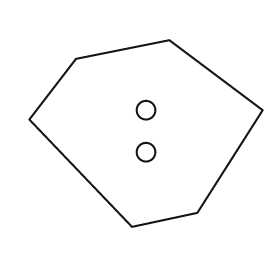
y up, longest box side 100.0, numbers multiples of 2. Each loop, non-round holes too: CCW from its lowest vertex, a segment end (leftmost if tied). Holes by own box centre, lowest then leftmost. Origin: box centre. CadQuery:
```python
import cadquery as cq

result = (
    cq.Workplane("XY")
    .moveTo(-6.0, -40.0)
    .lineTo(22.0, -34.0)
    .lineTo(50.0, 10.0)
    .lineTo(10.0, 40.0)
    .lineTo(-30.0, 32.0)
    .lineTo(-50.0, 6.0)
    .close()
    .moveTo(0.0, -8.0)
    .circle(4.0)
    .moveTo(0.0, 10.0)
    .circle(4.0)
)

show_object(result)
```